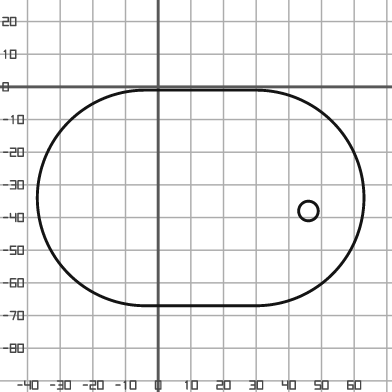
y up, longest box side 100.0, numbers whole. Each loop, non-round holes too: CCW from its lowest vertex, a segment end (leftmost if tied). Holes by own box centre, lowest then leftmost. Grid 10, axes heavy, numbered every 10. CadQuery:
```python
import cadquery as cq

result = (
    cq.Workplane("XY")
    .moveTo(-4.0, -67.0)
    .lineTo(30.0, -67.0)
    .threePointArc((63.0, -34.0), (30.0, -1.0))
    .lineTo(-4.0, -1.0)
    .threePointArc((-37.0, -34.0), (-4.0, -67.0))
    .close()
    .moveTo(46.0, -38.0)
    .circle(3.0)
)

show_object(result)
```